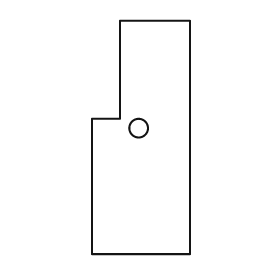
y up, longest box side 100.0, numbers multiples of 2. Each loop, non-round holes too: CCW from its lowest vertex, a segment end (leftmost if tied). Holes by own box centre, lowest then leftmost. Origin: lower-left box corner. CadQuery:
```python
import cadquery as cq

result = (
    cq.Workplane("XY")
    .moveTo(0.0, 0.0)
    .lineTo(42.0, 0.0)
    .lineTo(42.0, 100.0)
    .lineTo(12.0, 100.0)
    .lineTo(12.0, 58.0)
    .lineTo(0.0, 58.0)
    .close()
    .moveTo(20.0, 54.0)
    .circle(4.0)
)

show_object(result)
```